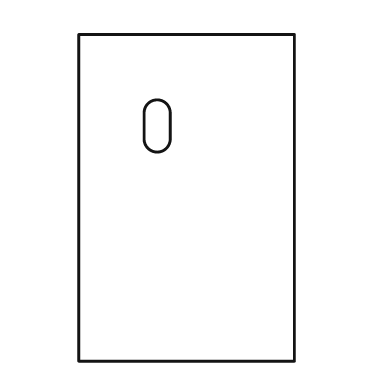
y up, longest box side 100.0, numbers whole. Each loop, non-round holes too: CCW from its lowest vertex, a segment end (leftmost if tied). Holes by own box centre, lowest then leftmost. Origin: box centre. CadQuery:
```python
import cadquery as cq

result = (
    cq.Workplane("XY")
    .moveTo(-33.0, -50.0)
    .lineTo(33.0, -50.0)
    .lineTo(33.0, 50.0)
    .lineTo(-33.0, 50.0)
    .close()
    .moveTo(-13.0, 18.0)
    .threePointArc((-9.0, 14.0), (-5.0, 18.0))
    .lineTo(-5.0, 26.0)
    .threePointArc((-9.0, 30.0), (-13.0, 26.0))
    .close()
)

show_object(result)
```